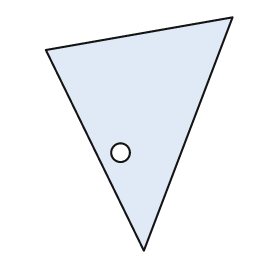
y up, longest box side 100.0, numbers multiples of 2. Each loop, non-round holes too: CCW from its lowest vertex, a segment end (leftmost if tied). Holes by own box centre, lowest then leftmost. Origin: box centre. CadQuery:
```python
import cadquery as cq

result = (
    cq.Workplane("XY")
    .moveTo(2.0, -50.0)
    .lineTo(40.0, 50.0)
    .lineTo(-40.0, 36.0)
    .close()
    .moveTo(-8.0, -8.0)
    .circle(4.0)
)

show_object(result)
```